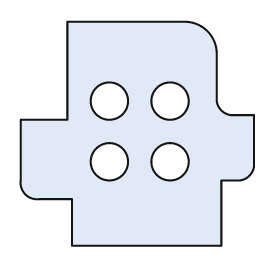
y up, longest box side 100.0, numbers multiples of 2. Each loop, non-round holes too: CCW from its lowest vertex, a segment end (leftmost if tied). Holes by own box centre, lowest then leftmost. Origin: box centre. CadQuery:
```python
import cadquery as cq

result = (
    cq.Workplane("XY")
    .moveTo(-28.0, -48.0)
    .lineTo(36.0, -48.0)
    .lineTo(36.0, -20.0)
    .lineTo(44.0, -20.0)
    .threePointArc((48.0, -18.0), (50.0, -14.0))
    .lineTo(50.0, 8.0)
    .lineTo(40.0, 8.0)
    .threePointArc((36.0, 10.0), (34.0, 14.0))
    .lineTo(34.0, 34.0)
    .threePointArc((30.0, 44.0), (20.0, 48.0))
    .lineTo(-30.0, 48.0)
    .lineTo(-30.0, 6.0)
    .lineTo(-50.0, 6.0)
    .lineTo(-50.0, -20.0)
    .threePointArc((-48.0, -26.0), (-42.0, -28.0))
    .lineTo(-28.0, -28.0)
    .close()
    .moveTo(-12.0, -12.0)
    .circle(8.0)
    .moveTo(14.0, -12.0)
    .circle(8.0)
    .moveTo(-12.0, 14.0)
    .circle(8.0)
    .moveTo(14.0, 14.0)
    .circle(8.0)
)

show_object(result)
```